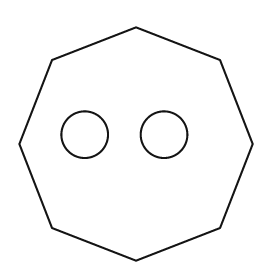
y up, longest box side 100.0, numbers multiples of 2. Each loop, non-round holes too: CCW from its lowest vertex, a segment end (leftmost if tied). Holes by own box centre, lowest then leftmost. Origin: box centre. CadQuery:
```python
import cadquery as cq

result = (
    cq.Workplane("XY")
    .moveTo(0.0, -50.0)
    .lineTo(36.0, -36.0)
    .lineTo(50.0, 0.0)
    .lineTo(36.0, 36.0)
    .lineTo(0.0, 50.0)
    .lineTo(-36.0, 36.0)
    .lineTo(-50.0, 0.0)
    .lineTo(-36.0, -36.0)
    .close()
    .moveTo(-22.0, 4.0)
    .circle(10.0)
    .moveTo(12.0, 4.0)
    .circle(10.0)
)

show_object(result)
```